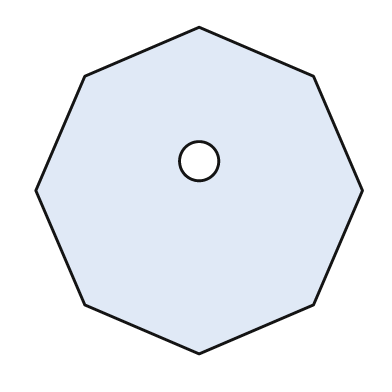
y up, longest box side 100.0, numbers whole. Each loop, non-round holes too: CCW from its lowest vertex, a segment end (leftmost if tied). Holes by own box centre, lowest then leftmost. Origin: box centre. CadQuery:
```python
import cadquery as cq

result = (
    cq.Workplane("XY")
    .moveTo(0.0, -50.0)
    .lineTo(35.0, -35.0)
    .lineTo(50.0, 0.0)
    .lineTo(35.0, 35.0)
    .lineTo(0.0, 50.0)
    .lineTo(-35.0, 35.0)
    .lineTo(-50.0, 0.0)
    .lineTo(-35.0, -35.0)
    .close()
    .moveTo(0.0, 9.0)
    .circle(6.0)
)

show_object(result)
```